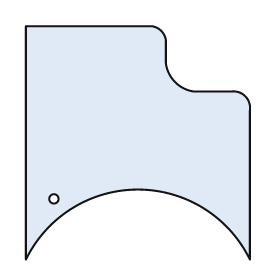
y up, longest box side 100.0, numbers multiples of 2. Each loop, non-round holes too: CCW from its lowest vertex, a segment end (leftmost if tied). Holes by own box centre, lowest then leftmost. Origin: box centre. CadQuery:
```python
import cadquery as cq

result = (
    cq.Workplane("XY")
    .moveTo(-48.0, -50.0)
    .threePointArc((0.0, -20.0), (48.0, -50.0))
    .lineTo(48.0, 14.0)
    .threePointArc((46.0, 20.0), (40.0, 22.0))
    .lineTo(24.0, 22.0)
    .threePointArc((16.0, 26.0), (12.0, 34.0))
    .lineTo(12.0, 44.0)
    .threePointArc((10.0, 48.0), (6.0, 50.0))
    .lineTo(-48.0, 50.0)
    .close()
    .moveTo(-36.0, -24.0)
    .circle(2.0)
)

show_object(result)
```